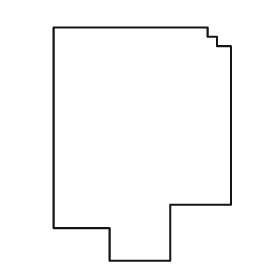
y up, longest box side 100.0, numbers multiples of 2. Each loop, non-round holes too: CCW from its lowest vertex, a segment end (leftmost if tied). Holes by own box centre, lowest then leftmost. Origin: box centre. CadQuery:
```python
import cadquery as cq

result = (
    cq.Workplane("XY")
    .moveTo(-14.0, -50.0)
    .lineTo(12.0, -50.0)
    .lineTo(12.0, -26.0)
    .lineTo(38.0, -26.0)
    .lineTo(38.0, 42.0)
    .lineTo(32.0, 42.0)
    .lineTo(32.0, 46.0)
    .lineTo(28.0, 46.0)
    .lineTo(28.0, 50.0)
    .lineTo(-38.0, 50.0)
    .lineTo(-38.0, -36.0)
    .lineTo(-14.0, -36.0)
    .close()
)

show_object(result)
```